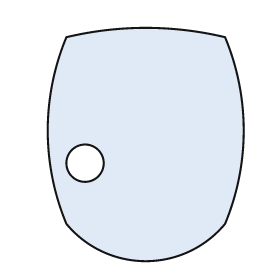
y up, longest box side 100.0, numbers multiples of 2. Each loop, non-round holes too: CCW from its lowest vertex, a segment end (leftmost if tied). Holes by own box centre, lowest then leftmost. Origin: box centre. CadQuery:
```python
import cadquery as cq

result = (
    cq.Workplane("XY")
    .moveTo(-34.0, -34.0)
    .threePointArc((0.0, -50.0), (34.0, -34.0))
    .threePointArc((42.0, 6.0), (34.0, 46.0))
    .threePointArc((0.0, 50.0), (-34.0, 46.0))
    .threePointArc((-42.0, 6.0), (-34.0, -34.0))
    .close()
    .moveTo(-26.0, -8.0)
    .circle(8.0)
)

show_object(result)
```